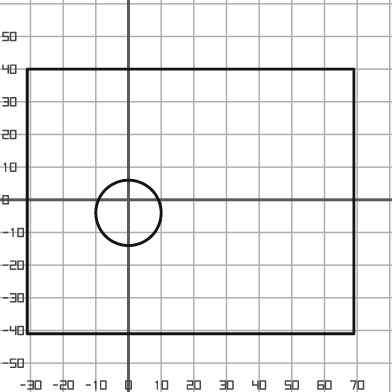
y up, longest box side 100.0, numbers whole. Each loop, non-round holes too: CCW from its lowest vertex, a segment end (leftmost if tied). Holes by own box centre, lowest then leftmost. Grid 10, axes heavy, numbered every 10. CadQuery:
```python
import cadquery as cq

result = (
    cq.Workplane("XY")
    .moveTo(-31.0, -41.0)
    .lineTo(69.0, -41.0)
    .lineTo(69.0, 40.0)
    .lineTo(-31.0, 40.0)
    .close()
    .moveTo(0.0, -4.0)
    .circle(10.0)
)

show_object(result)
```